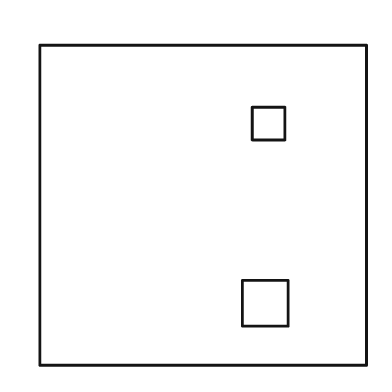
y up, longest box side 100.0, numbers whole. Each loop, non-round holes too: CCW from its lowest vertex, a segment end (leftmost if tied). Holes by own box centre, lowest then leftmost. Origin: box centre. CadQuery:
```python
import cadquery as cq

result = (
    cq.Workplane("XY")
    .moveTo(-50.0, -49.0)
    .lineTo(50.0, -49.0)
    .lineTo(50.0, 49.0)
    .lineTo(-50.0, 49.0)
    .close()
    .moveTo(12.0, -37.0)
    .lineTo(26.0, -37.0)
    .lineTo(26.0, -23.0)
    .lineTo(12.0, -23.0)
    .close()
    .moveTo(15.0, 20.0)
    .lineTo(25.0, 20.0)
    .lineTo(25.0, 30.0)
    .lineTo(15.0, 30.0)
    .close()
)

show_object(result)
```